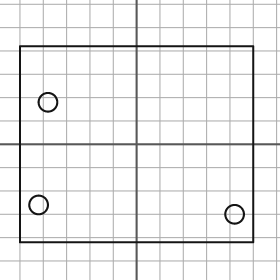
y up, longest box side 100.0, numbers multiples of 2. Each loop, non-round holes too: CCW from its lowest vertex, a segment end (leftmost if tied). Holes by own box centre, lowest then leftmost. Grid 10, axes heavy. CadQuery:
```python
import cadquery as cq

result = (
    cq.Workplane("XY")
    .moveTo(-50.0, -42.0)
    .lineTo(50.0, -42.0)
    .lineTo(50.0, 42.0)
    .lineTo(-50.0, 42.0)
    .close()
    .moveTo(42.0, -30.0)
    .circle(4.0)
    .moveTo(-42.0, -26.0)
    .circle(4.0)
    .moveTo(-38.0, 18.0)
    .circle(4.0)
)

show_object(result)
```